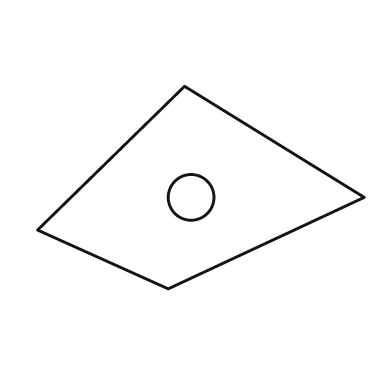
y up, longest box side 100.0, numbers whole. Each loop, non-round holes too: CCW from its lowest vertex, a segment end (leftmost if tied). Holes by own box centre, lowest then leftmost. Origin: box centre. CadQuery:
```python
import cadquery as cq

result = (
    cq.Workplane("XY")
    .moveTo(-10.0, -31.0)
    .lineTo(50.0, -3.0)
    .lineTo(-5.0, 31.0)
    .lineTo(-50.0, -13.0)
    .close()
    .moveTo(-3.0, -3.0)
    .circle(7.0)
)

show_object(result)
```